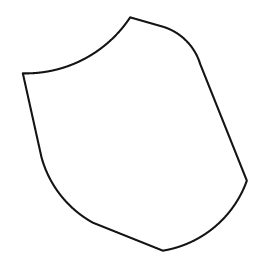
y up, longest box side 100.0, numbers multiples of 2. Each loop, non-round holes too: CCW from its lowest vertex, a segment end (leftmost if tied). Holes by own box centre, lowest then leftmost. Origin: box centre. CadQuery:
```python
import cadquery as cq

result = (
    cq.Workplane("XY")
    .moveTo(12.0, -50.0)
    .threePointArc((34.0, -40.0), (48.0, -20.0))
    .lineTo(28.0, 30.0)
    .threePointArc((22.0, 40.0), (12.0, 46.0))
    .lineTo(-2.0, 50.0)
    .threePointArc((-22.0, 32.0), (-48.0, 26.0))
    .lineTo(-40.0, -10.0)
    .threePointArc((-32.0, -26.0), (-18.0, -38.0))
    .close()
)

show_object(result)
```